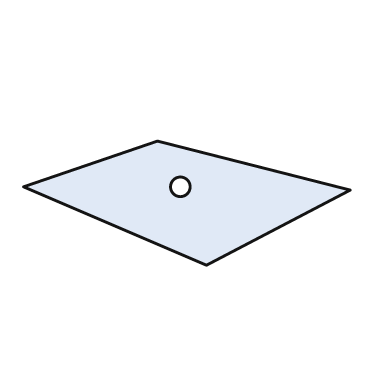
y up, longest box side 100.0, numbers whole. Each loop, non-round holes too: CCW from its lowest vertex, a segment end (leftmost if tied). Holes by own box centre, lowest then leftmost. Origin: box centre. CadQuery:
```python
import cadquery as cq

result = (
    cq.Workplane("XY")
    .moveTo(6.0, -19.0)
    .lineTo(50.0, 4.0)
    .lineTo(-9.0, 19.0)
    .lineTo(-50.0, 5.0)
    .close()
    .moveTo(-2.0, 5.0)
    .circle(3.0)
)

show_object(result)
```